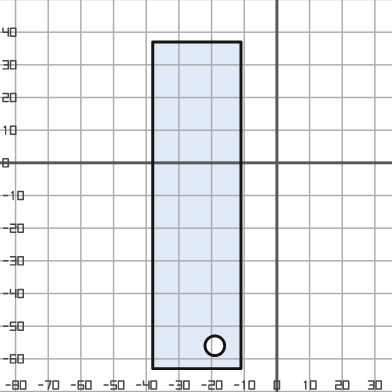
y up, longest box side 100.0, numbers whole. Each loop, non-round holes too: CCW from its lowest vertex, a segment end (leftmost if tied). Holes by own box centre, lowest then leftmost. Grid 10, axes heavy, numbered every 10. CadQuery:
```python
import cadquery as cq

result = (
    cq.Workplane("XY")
    .moveTo(-38.0, -63.0)
    .lineTo(-11.0, -63.0)
    .lineTo(-11.0, 37.0)
    .lineTo(-38.0, 37.0)
    .close()
    .moveTo(-19.0, -56.0)
    .circle(3.0)
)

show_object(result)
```